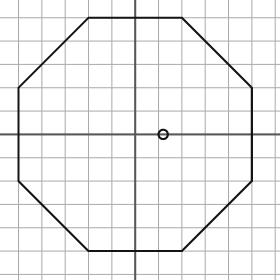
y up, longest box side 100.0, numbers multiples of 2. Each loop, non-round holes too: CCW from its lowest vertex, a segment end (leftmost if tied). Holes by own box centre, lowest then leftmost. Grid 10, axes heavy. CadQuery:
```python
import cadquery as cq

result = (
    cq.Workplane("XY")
    .moveTo(-20.0, -50.0)
    .lineTo(20.0, -50.0)
    .lineTo(50.0, -20.0)
    .lineTo(50.0, 20.0)
    .lineTo(20.0, 50.0)
    .lineTo(-20.0, 50.0)
    .lineTo(-50.0, 20.0)
    .lineTo(-50.0, -20.0)
    .close()
    .moveTo(12.0, 0.0)
    .circle(2.0)
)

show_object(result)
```